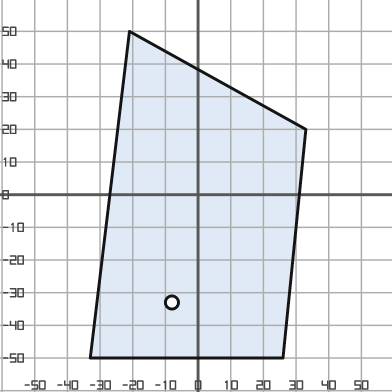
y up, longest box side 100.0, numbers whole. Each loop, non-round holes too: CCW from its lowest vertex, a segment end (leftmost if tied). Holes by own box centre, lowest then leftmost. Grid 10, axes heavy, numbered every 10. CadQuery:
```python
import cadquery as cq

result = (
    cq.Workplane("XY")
    .moveTo(-33.0, -50.0)
    .lineTo(26.0, -50.0)
    .lineTo(33.0, 20.0)
    .lineTo(-21.0, 50.0)
    .close()
    .moveTo(-8.0, -33.0)
    .circle(2.0)
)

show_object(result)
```